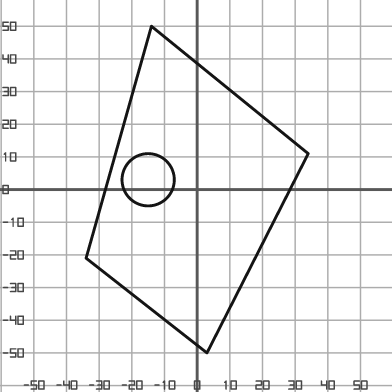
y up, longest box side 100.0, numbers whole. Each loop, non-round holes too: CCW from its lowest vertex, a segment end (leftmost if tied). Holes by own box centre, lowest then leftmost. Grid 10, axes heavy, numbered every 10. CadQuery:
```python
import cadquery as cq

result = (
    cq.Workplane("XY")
    .moveTo(3.0, -50.0)
    .lineTo(34.0, 11.0)
    .lineTo(-14.0, 50.0)
    .lineTo(-34.0, -21.0)
    .close()
    .moveTo(-15.0, 3.0)
    .circle(8.0)
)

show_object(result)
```